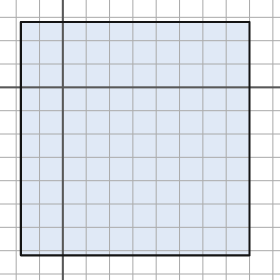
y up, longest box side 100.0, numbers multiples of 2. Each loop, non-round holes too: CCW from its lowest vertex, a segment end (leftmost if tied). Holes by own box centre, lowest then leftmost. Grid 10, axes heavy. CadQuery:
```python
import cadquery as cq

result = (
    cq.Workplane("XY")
    .moveTo(-18.0, -72.0)
    .lineTo(80.0, -72.0)
    .lineTo(80.0, 28.0)
    .lineTo(-18.0, 28.0)
    .close()
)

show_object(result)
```